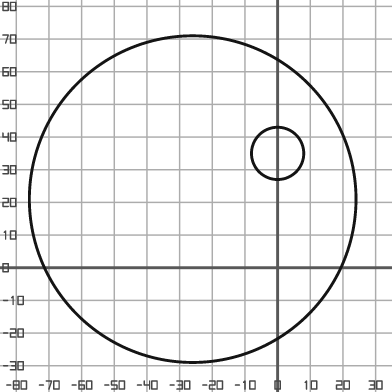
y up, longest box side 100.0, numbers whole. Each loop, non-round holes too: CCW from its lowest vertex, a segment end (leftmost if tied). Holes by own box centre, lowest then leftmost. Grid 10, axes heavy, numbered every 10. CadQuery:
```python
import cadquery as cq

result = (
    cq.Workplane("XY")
    .moveTo(-26.0, 21.0)
    .circle(50.0)
    .moveTo(0.0, 35.0)
    .circle(8.0)
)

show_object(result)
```